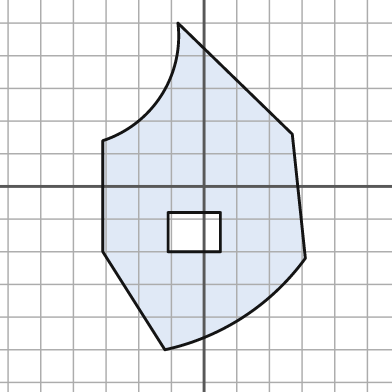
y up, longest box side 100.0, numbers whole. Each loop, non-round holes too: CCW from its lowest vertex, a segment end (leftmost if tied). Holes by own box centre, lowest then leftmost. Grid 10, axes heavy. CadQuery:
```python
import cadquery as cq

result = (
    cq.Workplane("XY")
    .moveTo(-12.0, -50.0)
    .threePointArc((12.0, -40.0), (31.0, -22.0))
    .lineTo(27.0, 16.0)
    .lineTo(-8.0, 50.0)
    .threePointArc((-13.0, 28.0), (-31.0, 14.0))
    .lineTo(-31.0, -20.0)
    .close()
    .moveTo(-11.0, -20.0)
    .lineTo(5.0, -20.0)
    .lineTo(5.0, -8.0)
    .lineTo(-11.0, -8.0)
    .close()
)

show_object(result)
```